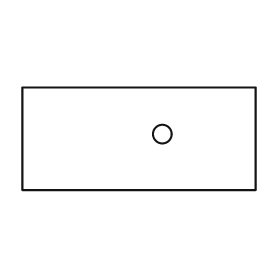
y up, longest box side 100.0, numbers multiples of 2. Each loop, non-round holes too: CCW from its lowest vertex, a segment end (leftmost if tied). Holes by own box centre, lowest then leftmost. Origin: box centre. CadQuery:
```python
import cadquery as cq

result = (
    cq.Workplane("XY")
    .moveTo(-50.0, -22.0)
    .lineTo(50.0, -22.0)
    .lineTo(50.0, 22.0)
    .lineTo(-50.0, 22.0)
    .close()
    .moveTo(10.0, 2.0)
    .circle(4.0)
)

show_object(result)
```